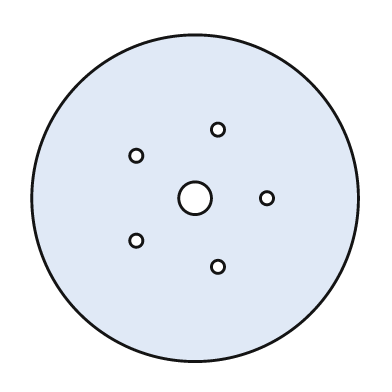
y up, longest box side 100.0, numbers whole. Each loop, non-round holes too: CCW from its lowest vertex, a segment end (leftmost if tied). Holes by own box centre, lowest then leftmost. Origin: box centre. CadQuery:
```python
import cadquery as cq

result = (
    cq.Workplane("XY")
    .moveTo(0.0, 0.0)
    .circle(50.0)
    .moveTo(7.0, -21.0)
    .circle(2.0)
    .moveTo(-18.0, -13.0)
    .circle(2.0)
    .moveTo(0.0, 0.0)
    .circle(5.0)
    .moveTo(22.0, 0.0)
    .circle(2.0)
    .moveTo(-18.0, 13.0)
    .circle(2.0)
    .moveTo(7.0, 21.0)
    .circle(2.0)
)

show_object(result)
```